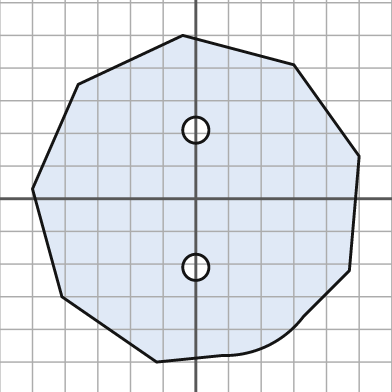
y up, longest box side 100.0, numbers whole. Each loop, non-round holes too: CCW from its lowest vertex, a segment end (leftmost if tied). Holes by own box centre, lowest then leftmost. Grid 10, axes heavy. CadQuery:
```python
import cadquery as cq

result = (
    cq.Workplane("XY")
    .moveTo(-12.0, -50.0)
    .lineTo(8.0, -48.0)
    .threePointArc((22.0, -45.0), (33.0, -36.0))
    .lineTo(47.0, -22.0)
    .lineTo(50.0, 13.0)
    .lineTo(30.0, 41.0)
    .lineTo(-4.0, 50.0)
    .lineTo(-36.0, 35.0)
    .lineTo(-50.0, 3.0)
    .lineTo(-41.0, -30.0)
    .close()
    .moveTo(0.0, -21.0)
    .circle(4.0)
    .moveTo(0.0, 21.0)
    .circle(4.0)
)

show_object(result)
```